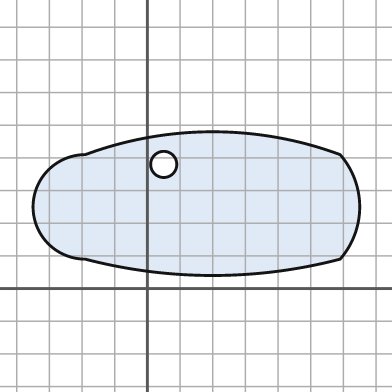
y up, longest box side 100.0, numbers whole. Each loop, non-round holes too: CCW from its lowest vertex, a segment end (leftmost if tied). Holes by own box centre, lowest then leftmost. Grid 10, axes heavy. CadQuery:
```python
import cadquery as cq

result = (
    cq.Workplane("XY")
    .moveTo(-19.0, 9.0)
    .threePointArc((20.0, 4.0), (59.0, 9.0))
    .threePointArc((65.0, 25.0), (59.0, 41.0))
    .threePointArc((20.0, 48.0), (-19.0, 41.0))
    .threePointArc((-35.0, 25.0), (-19.0, 9.0))
    .close()
    .moveTo(5.0, 38.0)
    .circle(4.0)
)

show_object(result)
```